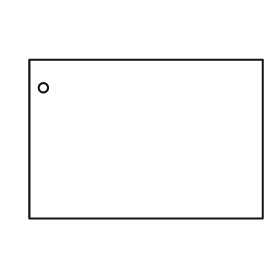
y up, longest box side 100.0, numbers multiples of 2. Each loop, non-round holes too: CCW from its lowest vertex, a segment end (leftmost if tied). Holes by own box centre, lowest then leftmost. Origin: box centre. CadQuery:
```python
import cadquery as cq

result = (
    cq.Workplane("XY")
    .moveTo(-50.0, -34.0)
    .lineTo(50.0, -34.0)
    .lineTo(50.0, 34.0)
    .lineTo(-50.0, 34.0)
    .close()
    .moveTo(-44.0, 22.0)
    .circle(2.0)
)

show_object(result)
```